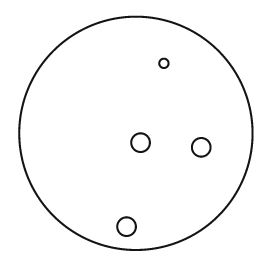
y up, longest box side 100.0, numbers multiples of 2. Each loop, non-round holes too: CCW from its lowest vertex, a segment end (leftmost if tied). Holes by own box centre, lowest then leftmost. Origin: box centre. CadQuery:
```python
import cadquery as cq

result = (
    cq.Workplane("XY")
    .moveTo(0.0, 0.0)
    .circle(50.0)
    .moveTo(-4.0, -40.0)
    .circle(4.0)
    .moveTo(28.0, -6.0)
    .circle(4.0)
    .moveTo(2.0, -4.0)
    .circle(4.0)
    .moveTo(12.0, 30.0)
    .circle(2.0)
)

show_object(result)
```